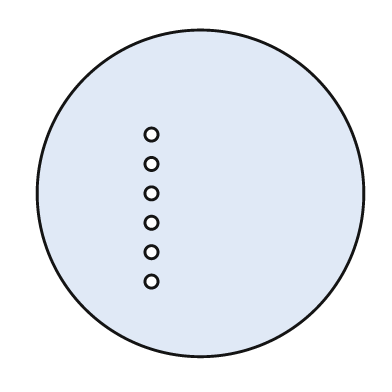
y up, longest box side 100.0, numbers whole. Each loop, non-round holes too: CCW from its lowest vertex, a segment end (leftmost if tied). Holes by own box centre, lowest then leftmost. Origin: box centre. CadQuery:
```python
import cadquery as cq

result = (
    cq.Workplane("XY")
    .moveTo(0.0, 0.0)
    .circle(50.0)
    .moveTo(-15.0, -27.0)
    .circle(2.0)
    .moveTo(-15.0, -18.0)
    .circle(2.0)
    .moveTo(-15.0, -9.0)
    .circle(2.0)
    .moveTo(-15.0, 0.0)
    .circle(2.0)
    .moveTo(-15.0, 9.0)
    .circle(2.0)
    .moveTo(-15.0, 18.0)
    .circle(2.0)
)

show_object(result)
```